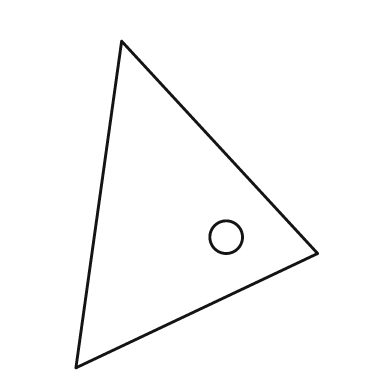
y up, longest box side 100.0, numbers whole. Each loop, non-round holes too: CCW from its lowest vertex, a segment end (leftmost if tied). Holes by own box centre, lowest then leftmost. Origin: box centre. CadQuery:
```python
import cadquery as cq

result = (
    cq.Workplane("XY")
    .moveTo(-37.0, -50.0)
    .lineTo(37.0, -15.0)
    .lineTo(-23.0, 50.0)
    .close()
    .moveTo(9.0, -10.0)
    .circle(5.0)
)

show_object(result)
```